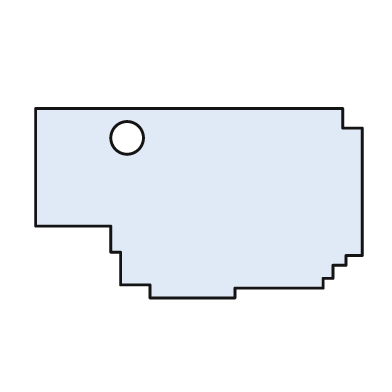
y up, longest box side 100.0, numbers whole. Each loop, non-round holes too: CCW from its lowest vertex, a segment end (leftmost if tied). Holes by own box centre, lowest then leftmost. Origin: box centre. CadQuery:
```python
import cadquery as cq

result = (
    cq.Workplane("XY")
    .moveTo(-15.0, -29.0)
    .lineTo(11.0, -29.0)
    .lineTo(11.0, -26.0)
    .lineTo(38.0, -26.0)
    .lineTo(38.0, -23.0)
    .lineTo(41.0, -23.0)
    .lineTo(41.0, -19.0)
    .lineTo(45.0, -19.0)
    .lineTo(45.0, -16.0)
    .lineTo(50.0, -16.0)
    .lineTo(50.0, 23.0)
    .lineTo(44.0, 23.0)
    .lineTo(44.0, 29.0)
    .lineTo(-50.0, 29.0)
    .lineTo(-50.0, -7.0)
    .lineTo(-27.0, -7.0)
    .lineTo(-27.0, -15.0)
    .lineTo(-24.0, -15.0)
    .lineTo(-24.0, -25.0)
    .lineTo(-15.0, -25.0)
    .close()
    .moveTo(-22.0, 20.0)
    .circle(5.0)
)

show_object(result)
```